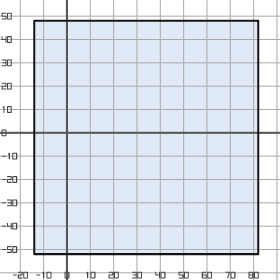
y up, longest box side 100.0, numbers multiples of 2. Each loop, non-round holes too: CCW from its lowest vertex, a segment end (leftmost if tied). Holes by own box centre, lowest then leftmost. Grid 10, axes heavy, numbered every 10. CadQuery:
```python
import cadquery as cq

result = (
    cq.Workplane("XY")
    .moveTo(-14.0, -52.0)
    .lineTo(82.0, -52.0)
    .lineTo(82.0, 48.0)
    .lineTo(-14.0, 48.0)
    .close()
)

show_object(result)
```